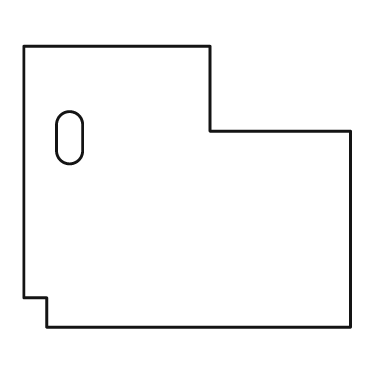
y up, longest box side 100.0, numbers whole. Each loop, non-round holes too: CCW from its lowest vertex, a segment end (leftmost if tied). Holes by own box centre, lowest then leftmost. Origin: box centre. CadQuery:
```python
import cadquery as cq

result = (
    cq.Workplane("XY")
    .moveTo(-43.0, -43.0)
    .lineTo(50.0, -43.0)
    .lineTo(50.0, 17.0)
    .lineTo(7.0, 17.0)
    .lineTo(7.0, 43.0)
    .lineTo(-50.0, 43.0)
    .lineTo(-50.0, -34.0)
    .lineTo(-43.0, -34.0)
    .close()
    .moveTo(-40.0, 11.0)
    .threePointArc((-36.0, 7.0), (-32.0, 11.0))
    .lineTo(-32.0, 19.0)
    .threePointArc((-36.0, 23.0), (-40.0, 19.0))
    .close()
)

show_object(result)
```